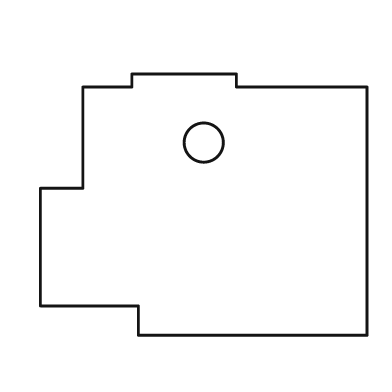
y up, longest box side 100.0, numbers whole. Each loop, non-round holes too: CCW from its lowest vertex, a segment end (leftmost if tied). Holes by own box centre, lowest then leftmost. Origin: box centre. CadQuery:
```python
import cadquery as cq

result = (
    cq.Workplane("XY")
    .moveTo(-20.0, -40.0)
    .lineTo(50.0, -40.0)
    .lineTo(50.0, 36.0)
    .lineTo(10.0, 36.0)
    .lineTo(10.0, 40.0)
    .lineTo(-22.0, 40.0)
    .lineTo(-22.0, 36.0)
    .lineTo(-37.0, 36.0)
    .lineTo(-37.0, 5.0)
    .lineTo(-50.0, 5.0)
    .lineTo(-50.0, -31.0)
    .lineTo(-20.0, -31.0)
    .close()
    .moveTo(0.0, 19.0)
    .circle(6.0)
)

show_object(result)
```